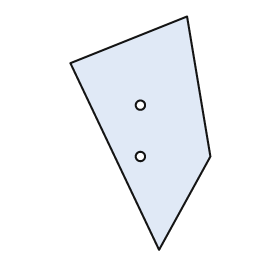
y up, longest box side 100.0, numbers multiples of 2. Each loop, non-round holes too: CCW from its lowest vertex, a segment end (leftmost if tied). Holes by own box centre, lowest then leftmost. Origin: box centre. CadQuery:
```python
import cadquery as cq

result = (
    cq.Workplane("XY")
    .moveTo(8.0, -50.0)
    .lineTo(30.0, -10.0)
    .lineTo(20.0, 50.0)
    .lineTo(-30.0, 30.0)
    .close()
    .moveTo(0.0, -10.0)
    .circle(2.0)
    .moveTo(0.0, 12.0)
    .circle(2.0)
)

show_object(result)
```